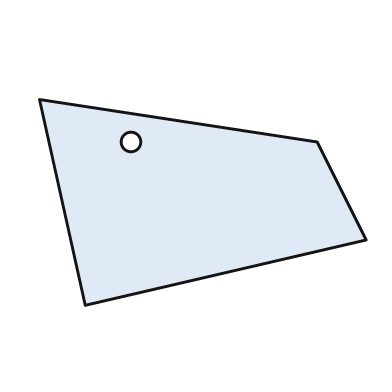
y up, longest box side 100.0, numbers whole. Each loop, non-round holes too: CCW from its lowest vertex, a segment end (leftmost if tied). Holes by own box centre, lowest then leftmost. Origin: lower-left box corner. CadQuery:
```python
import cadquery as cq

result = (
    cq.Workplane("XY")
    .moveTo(14.0, 0.0)
    .lineTo(100.0, 20.0)
    .lineTo(85.0, 50.0)
    .lineTo(0.0, 63.0)
    .close()
    .moveTo(28.0, 50.0)
    .circle(3.0)
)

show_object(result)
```